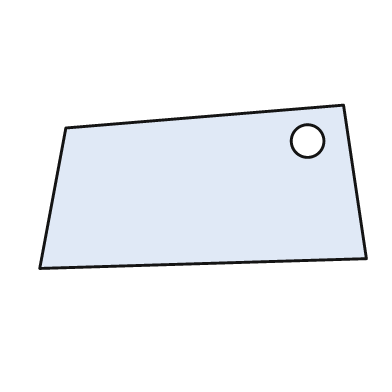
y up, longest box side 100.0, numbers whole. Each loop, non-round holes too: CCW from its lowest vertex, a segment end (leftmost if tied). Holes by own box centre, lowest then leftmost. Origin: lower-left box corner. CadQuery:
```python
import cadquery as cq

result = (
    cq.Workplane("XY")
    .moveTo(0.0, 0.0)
    .lineTo(100.0, 3.0)
    .lineTo(93.0, 50.0)
    .lineTo(8.0, 43.0)
    .close()
    .moveTo(82.0, 39.0)
    .circle(5.0)
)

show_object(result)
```